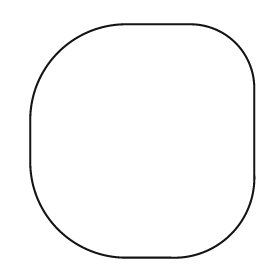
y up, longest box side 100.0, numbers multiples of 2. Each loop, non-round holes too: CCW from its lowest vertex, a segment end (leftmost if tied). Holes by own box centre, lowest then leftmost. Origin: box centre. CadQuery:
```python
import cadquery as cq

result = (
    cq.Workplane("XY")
    .moveTo(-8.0, -50.0)
    .lineTo(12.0, -50.0)
    .threePointArc((38.0, -40.0), (48.0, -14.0))
    .lineTo(48.0, 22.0)
    .threePointArc((40.0, 42.0), (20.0, 50.0))
    .lineTo(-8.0, 50.0)
    .threePointArc((-36.0, 38.0), (-48.0, 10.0))
    .lineTo(-48.0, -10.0)
    .threePointArc((-36.0, -38.0), (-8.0, -50.0))
    .close()
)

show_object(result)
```